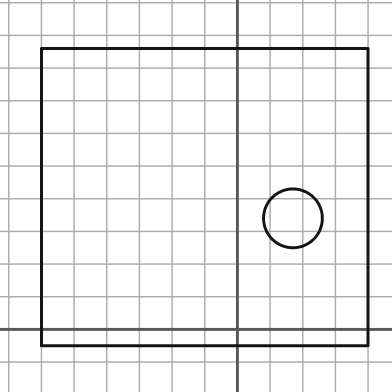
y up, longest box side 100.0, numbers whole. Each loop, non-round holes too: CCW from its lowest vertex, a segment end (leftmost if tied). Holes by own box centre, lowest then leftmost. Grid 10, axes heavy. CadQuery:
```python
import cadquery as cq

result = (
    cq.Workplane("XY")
    .moveTo(-60.0, -5.0)
    .lineTo(40.0, -5.0)
    .lineTo(40.0, 86.0)
    .lineTo(-60.0, 86.0)
    .close()
    .moveTo(17.0, 34.0)
    .circle(9.0)
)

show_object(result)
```